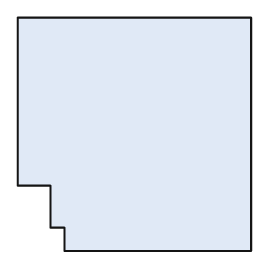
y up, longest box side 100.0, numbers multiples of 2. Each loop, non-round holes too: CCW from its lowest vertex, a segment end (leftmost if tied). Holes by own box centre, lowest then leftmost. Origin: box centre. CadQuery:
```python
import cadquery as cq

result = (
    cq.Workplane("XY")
    .moveTo(-30.0, -50.0)
    .lineTo(50.0, -50.0)
    .lineTo(50.0, 50.0)
    .lineTo(-50.0, 50.0)
    .lineTo(-50.0, -22.0)
    .lineTo(-36.0, -22.0)
    .lineTo(-36.0, -40.0)
    .lineTo(-30.0, -40.0)
    .close()
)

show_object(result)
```